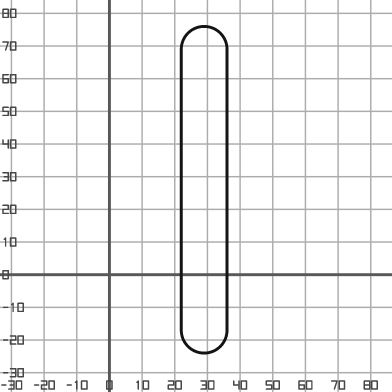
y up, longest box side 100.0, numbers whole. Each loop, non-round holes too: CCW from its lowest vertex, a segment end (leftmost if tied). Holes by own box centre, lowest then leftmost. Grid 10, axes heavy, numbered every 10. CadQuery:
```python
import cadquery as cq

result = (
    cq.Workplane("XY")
    .moveTo(22.0, -17.0)
    .threePointArc((29.0, -24.0), (36.0, -17.0))
    .lineTo(36.0, 69.0)
    .threePointArc((29.0, 76.0), (22.0, 69.0))
    .close()
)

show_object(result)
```